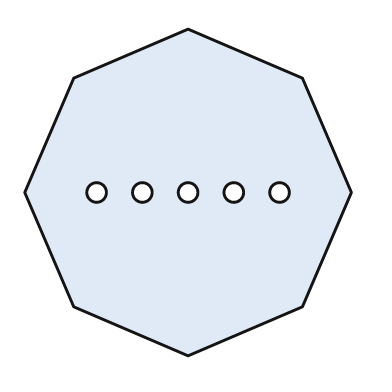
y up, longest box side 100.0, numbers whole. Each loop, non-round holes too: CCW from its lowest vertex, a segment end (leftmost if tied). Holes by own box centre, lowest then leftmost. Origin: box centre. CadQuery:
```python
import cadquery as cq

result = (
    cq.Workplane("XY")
    .moveTo(0.0, -50.0)
    .lineTo(35.0, -35.0)
    .lineTo(50.0, 0.0)
    .lineTo(35.0, 35.0)
    .lineTo(0.0, 50.0)
    .lineTo(-35.0, 35.0)
    .lineTo(-50.0, 0.0)
    .lineTo(-35.0, -35.0)
    .close()
    .moveTo(-28.0, 0.0)
    .circle(3.0)
    .moveTo(-14.0, 0.0)
    .circle(3.0)
    .moveTo(0.0, 0.0)
    .circle(3.0)
    .moveTo(14.0, 0.0)
    .circle(3.0)
    .moveTo(28.0, 0.0)
    .circle(3.0)
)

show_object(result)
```